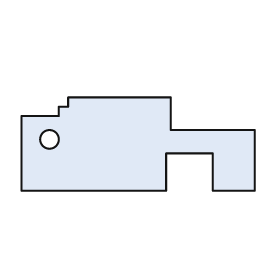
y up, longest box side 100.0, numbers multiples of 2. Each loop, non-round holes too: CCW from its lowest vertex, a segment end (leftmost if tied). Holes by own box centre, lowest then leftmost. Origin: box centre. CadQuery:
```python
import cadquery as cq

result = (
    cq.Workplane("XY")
    .moveTo(-50.0, -20.0)
    .lineTo(12.0, -20.0)
    .lineTo(12.0, -4.0)
    .lineTo(32.0, -4.0)
    .lineTo(32.0, -20.0)
    .lineTo(50.0, -20.0)
    .lineTo(50.0, 6.0)
    .lineTo(14.0, 6.0)
    .lineTo(14.0, 20.0)
    .lineTo(-30.0, 20.0)
    .lineTo(-30.0, 16.0)
    .lineTo(-34.0, 16.0)
    .lineTo(-34.0, 12.0)
    .lineTo(-50.0, 12.0)
    .close()
    .moveTo(-38.0, 2.0)
    .circle(4.0)
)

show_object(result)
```